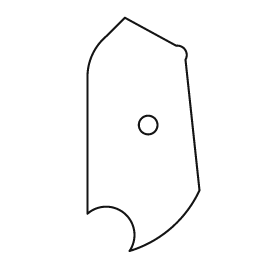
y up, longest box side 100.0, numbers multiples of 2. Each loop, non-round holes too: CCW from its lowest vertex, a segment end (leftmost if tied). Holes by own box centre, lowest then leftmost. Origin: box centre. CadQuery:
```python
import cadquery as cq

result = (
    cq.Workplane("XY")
    .moveTo(-6.0, -50.0)
    .threePointArc((12.0, -40.0), (24.0, -24.0))
    .lineTo(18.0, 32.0)
    .threePointArc((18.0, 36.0), (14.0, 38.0))
    .lineTo(-8.0, 50.0)
    .lineTo(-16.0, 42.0)
    .threePointArc((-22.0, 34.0), (-24.0, 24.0))
    .lineTo(-24.0, -34.0)
    .threePointArc((-8.0, -34.0), (-6.0, -50.0))
    .close()
    .moveTo(2.0, 4.0)
    .circle(4.0)
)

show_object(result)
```